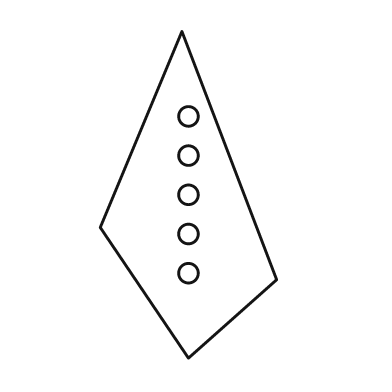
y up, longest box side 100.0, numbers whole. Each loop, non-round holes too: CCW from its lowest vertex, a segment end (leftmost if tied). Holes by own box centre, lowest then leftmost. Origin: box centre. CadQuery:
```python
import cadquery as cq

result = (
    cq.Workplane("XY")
    .moveTo(0.0, -50.0)
    .lineTo(27.0, -26.0)
    .lineTo(-2.0, 50.0)
    .lineTo(-27.0, -10.0)
    .close()
    .moveTo(0.0, -24.0)
    .circle(3.0)
    .moveTo(0.0, -12.0)
    .circle(3.0)
    .moveTo(0.0, 0.0)
    .circle(3.0)
    .moveTo(0.0, 12.0)
    .circle(3.0)
    .moveTo(0.0, 24.0)
    .circle(3.0)
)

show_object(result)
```